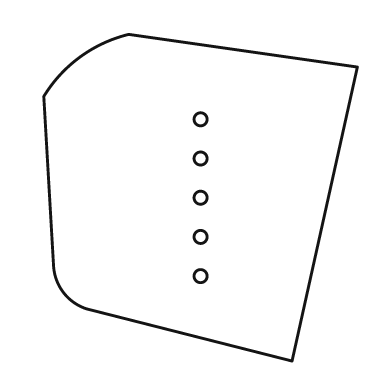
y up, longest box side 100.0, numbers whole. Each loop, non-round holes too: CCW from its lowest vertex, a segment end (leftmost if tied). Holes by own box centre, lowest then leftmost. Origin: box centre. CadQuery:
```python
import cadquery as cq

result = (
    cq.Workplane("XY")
    .moveTo(28.0, -50.0)
    .lineTo(48.0, 40.0)
    .lineTo(-22.0, 50.0)
    .threePointArc((-37.0, 43.0), (-48.0, 31.0))
    .lineTo(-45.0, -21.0)
    .threePointArc((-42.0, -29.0), (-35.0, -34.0))
    .close()
    .moveTo(0.0, -24.0)
    .circle(2.0)
    .moveTo(0.0, -12.0)
    .circle(2.0)
    .moveTo(0.0, 0.0)
    .circle(2.0)
    .moveTo(0.0, 12.0)
    .circle(2.0)
    .moveTo(0.0, 24.0)
    .circle(2.0)
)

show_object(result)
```